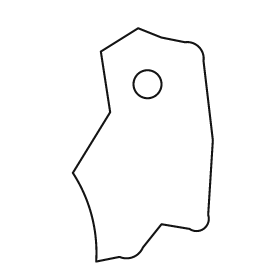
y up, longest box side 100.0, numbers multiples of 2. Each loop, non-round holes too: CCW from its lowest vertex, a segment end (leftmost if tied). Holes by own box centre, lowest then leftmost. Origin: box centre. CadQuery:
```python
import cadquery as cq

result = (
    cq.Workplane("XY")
    .moveTo(-20.0, -50.0)
    .lineTo(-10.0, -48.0)
    .threePointArc((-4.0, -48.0), (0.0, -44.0))
    .lineTo(8.0, -34.0)
    .lineTo(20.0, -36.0)
    .threePointArc((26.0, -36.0), (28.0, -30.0))
    .lineTo(30.0, 2.0)
    .lineTo(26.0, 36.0)
    .threePointArc((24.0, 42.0), (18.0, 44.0))
    .lineTo(8.0, 46.0)
    .lineTo(-2.0, 50.0)
    .lineTo(-18.0, 40.0)
    .lineTo(-14.0, 14.0)
    .lineTo(-30.0, -12.0)
    .threePointArc((-22.0, -30.0), (-20.0, -50.0))
    .close()
    .moveTo(2.0, 26.0)
    .circle(6.0)
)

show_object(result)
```